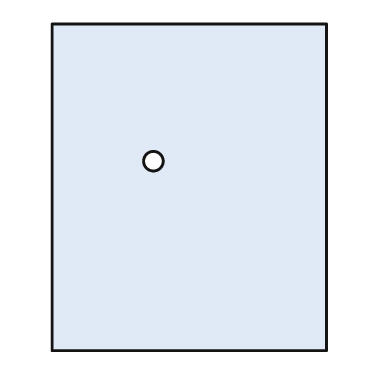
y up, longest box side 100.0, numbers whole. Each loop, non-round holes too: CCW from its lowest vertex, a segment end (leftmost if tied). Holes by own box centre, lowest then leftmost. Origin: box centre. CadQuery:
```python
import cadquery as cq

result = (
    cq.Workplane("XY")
    .moveTo(-42.0, -50.0)
    .lineTo(42.0, -50.0)
    .lineTo(42.0, 50.0)
    .lineTo(-42.0, 50.0)
    .close()
    .moveTo(-11.0, 8.0)
    .circle(3.0)
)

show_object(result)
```